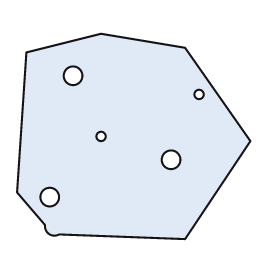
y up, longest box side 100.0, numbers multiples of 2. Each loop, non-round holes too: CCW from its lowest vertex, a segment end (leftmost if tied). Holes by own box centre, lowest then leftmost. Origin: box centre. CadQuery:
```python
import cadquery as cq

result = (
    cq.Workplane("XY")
    .moveTo(22.0, -44.0)
    .lineTo(50.0, -2.0)
    .lineTo(22.0, 38.0)
    .lineTo(-14.0, 44.0)
    .lineTo(-46.0, 36.0)
    .lineTo(-50.0, -24.0)
    .lineTo(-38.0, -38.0)
    .threePointArc((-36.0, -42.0), (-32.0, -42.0))
    .close()
    .moveTo(-36.0, -26.0)
    .circle(4.0)
    .moveTo(16.0, -10.0)
    .circle(4.0)
    .moveTo(-14.0, 0.0)
    .circle(2.0)
    .moveTo(28.0, 18.0)
    .circle(2.0)
    .moveTo(-26.0, 26.0)
    .circle(4.0)
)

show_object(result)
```